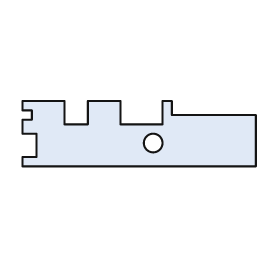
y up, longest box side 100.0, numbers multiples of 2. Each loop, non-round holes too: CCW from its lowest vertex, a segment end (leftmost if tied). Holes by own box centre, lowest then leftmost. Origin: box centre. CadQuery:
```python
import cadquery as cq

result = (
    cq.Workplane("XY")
    .moveTo(-50.0, -14.0)
    .lineTo(50.0, -14.0)
    .lineTo(50.0, 8.0)
    .lineTo(14.0, 8.0)
    .lineTo(14.0, 14.0)
    .lineTo(10.0, 14.0)
    .lineTo(10.0, 4.0)
    .lineTo(-8.0, 4.0)
    .lineTo(-8.0, 14.0)
    .lineTo(-22.0, 14.0)
    .lineTo(-22.0, 4.0)
    .lineTo(-32.0, 4.0)
    .lineTo(-32.0, 14.0)
    .lineTo(-50.0, 14.0)
    .lineTo(-50.0, 10.0)
    .lineTo(-46.0, 10.0)
    .lineTo(-46.0, 6.0)
    .lineTo(-50.0, 6.0)
    .lineTo(-50.0, 0.0)
    .lineTo(-44.0, 0.0)
    .lineTo(-44.0, -10.0)
    .lineTo(-50.0, -10.0)
    .close()
    .moveTo(6.0, -4.0)
    .circle(4.0)
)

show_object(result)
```